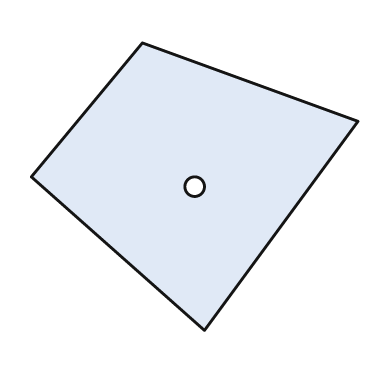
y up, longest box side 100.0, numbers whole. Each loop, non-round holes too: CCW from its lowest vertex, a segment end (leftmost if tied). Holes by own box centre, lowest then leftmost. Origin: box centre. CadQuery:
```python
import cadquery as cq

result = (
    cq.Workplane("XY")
    .moveTo(3.0, -44.0)
    .lineTo(50.0, 20.0)
    .lineTo(-16.0, 44.0)
    .lineTo(-50.0, 3.0)
    .close()
    .moveTo(0.0, 0.0)
    .circle(3.0)
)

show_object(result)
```